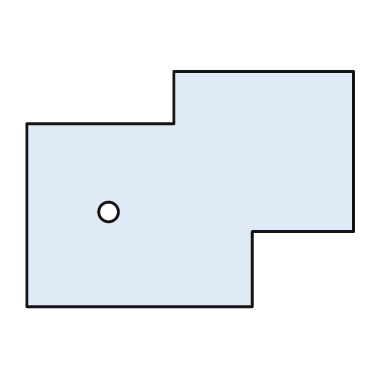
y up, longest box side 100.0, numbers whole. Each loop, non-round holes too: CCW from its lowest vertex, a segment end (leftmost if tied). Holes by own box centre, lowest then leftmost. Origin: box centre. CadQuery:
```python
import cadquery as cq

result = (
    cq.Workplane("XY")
    .moveTo(-50.0, -36.0)
    .lineTo(19.0, -36.0)
    .lineTo(19.0, -13.0)
    .lineTo(50.0, -13.0)
    .lineTo(50.0, 36.0)
    .lineTo(-5.0, 36.0)
    .lineTo(-5.0, 20.0)
    .lineTo(-50.0, 20.0)
    .close()
    .moveTo(-25.0, -7.0)
    .circle(3.0)
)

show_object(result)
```